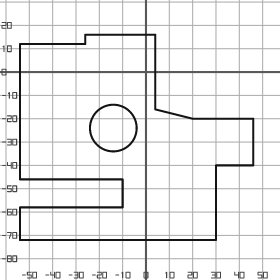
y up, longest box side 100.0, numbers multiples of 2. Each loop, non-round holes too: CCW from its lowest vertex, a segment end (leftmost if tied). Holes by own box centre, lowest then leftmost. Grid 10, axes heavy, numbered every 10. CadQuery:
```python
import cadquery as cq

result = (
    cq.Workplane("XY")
    .moveTo(-54.0, -72.0)
    .lineTo(30.0, -72.0)
    .lineTo(30.0, -40.0)
    .lineTo(46.0, -40.0)
    .lineTo(46.0, -20.0)
    .lineTo(20.0, -20.0)
    .lineTo(4.0, -16.0)
    .lineTo(4.0, 16.0)
    .lineTo(-26.0, 16.0)
    .lineTo(-26.0, 12.0)
    .lineTo(-54.0, 12.0)
    .lineTo(-54.0, -46.0)
    .lineTo(-10.0, -46.0)
    .lineTo(-10.0, -58.0)
    .lineTo(-54.0, -58.0)
    .close()
    .moveTo(-14.0, -24.0)
    .circle(10.0)
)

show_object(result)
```